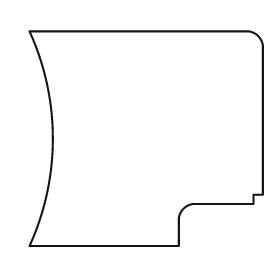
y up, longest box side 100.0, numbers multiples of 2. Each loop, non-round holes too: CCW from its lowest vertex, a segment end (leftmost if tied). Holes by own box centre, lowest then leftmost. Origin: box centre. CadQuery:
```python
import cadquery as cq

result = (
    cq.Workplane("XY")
    .moveTo(-50.0, -46.0)
    .lineTo(14.0, -46.0)
    .lineTo(14.0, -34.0)
    .threePointArc((16.0, -30.0), (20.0, -28.0))
    .lineTo(46.0, -28.0)
    .lineTo(46.0, -24.0)
    .lineTo(50.0, -24.0)
    .lineTo(50.0, 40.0)
    .threePointArc((48.0, 44.0), (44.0, 46.0))
    .lineTo(-50.0, 46.0)
    .threePointArc((-40.0, 0.0), (-50.0, -46.0))
    .close()
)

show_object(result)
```